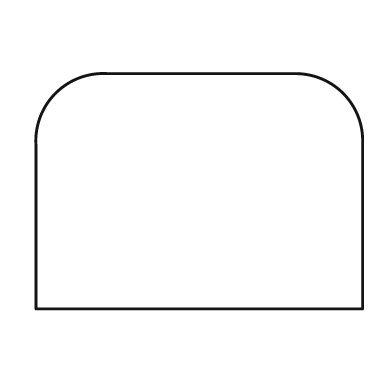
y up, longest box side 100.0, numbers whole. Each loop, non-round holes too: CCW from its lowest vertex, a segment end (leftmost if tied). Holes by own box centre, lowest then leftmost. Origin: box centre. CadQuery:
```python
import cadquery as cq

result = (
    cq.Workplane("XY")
    .moveTo(-50.0, -36.0)
    .lineTo(50.0, -36.0)
    .lineTo(50.0, 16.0)
    .threePointArc((44.0, 30.0), (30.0, 36.0))
    .lineTo(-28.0, 36.0)
    .threePointArc((-44.0, 30.0), (-50.0, 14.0))
    .close()
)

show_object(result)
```